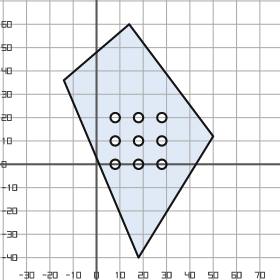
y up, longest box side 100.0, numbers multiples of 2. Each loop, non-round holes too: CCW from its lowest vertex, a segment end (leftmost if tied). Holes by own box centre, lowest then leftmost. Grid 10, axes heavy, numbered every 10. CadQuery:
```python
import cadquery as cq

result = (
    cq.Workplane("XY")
    .moveTo(18.0, -40.0)
    .lineTo(50.0, 12.0)
    .lineTo(14.0, 60.0)
    .lineTo(-14.0, 36.0)
    .close()
    .moveTo(8.0, 0.0)
    .circle(2.0)
    .moveTo(18.0, 0.0)
    .circle(2.0)
    .moveTo(28.0, 0.0)
    .circle(2.0)
    .moveTo(8.0, 10.0)
    .circle(2.0)
    .moveTo(18.0, 10.0)
    .circle(2.0)
    .moveTo(28.0, 10.0)
    .circle(2.0)
    .moveTo(8.0, 20.0)
    .circle(2.0)
    .moveTo(18.0, 20.0)
    .circle(2.0)
    .moveTo(28.0, 20.0)
    .circle(2.0)
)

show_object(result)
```